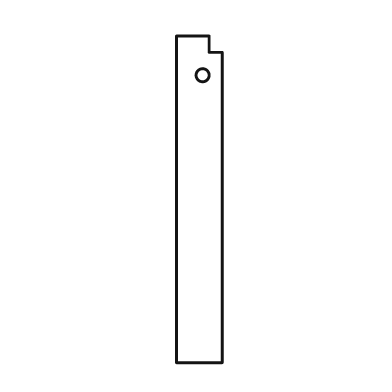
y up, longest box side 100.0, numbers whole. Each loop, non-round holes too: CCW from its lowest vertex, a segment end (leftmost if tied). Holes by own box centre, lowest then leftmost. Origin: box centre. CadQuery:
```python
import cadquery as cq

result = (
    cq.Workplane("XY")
    .moveTo(-7.0, -50.0)
    .lineTo(7.0, -50.0)
    .lineTo(7.0, 45.0)
    .lineTo(3.0, 45.0)
    .lineTo(3.0, 50.0)
    .lineTo(-7.0, 50.0)
    .close()
    .moveTo(1.0, 38.0)
    .circle(2.0)
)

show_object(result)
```